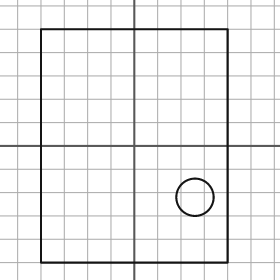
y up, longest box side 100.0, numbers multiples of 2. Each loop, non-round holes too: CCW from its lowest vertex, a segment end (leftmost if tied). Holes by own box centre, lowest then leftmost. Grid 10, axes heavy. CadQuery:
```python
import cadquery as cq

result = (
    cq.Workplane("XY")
    .moveTo(-40.0, -50.0)
    .lineTo(40.0, -50.0)
    .lineTo(40.0, 50.0)
    .lineTo(-40.0, 50.0)
    .close()
    .moveTo(26.0, -22.0)
    .circle(8.0)
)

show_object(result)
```